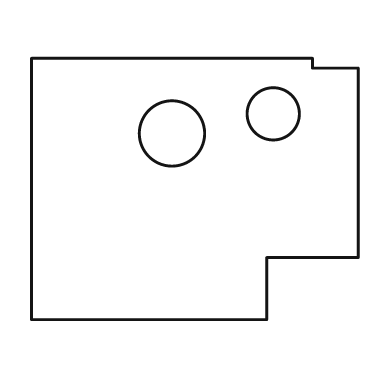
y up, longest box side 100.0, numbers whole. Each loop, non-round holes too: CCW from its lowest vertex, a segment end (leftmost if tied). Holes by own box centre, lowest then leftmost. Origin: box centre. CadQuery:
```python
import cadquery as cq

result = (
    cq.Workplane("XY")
    .moveTo(-50.0, -40.0)
    .lineTo(22.0, -40.0)
    .lineTo(22.0, -21.0)
    .lineTo(50.0, -21.0)
    .lineTo(50.0, 37.0)
    .lineTo(36.0, 37.0)
    .lineTo(36.0, 40.0)
    .lineTo(-50.0, 40.0)
    .close()
    .moveTo(-7.0, 17.0)
    .circle(10.0)
    .moveTo(24.0, 23.0)
    .circle(8.0)
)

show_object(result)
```